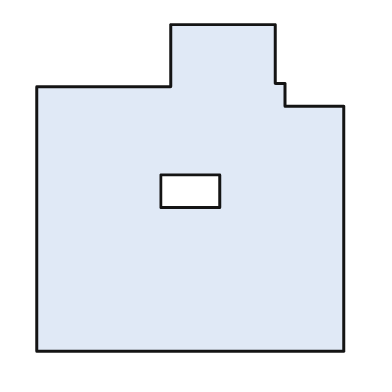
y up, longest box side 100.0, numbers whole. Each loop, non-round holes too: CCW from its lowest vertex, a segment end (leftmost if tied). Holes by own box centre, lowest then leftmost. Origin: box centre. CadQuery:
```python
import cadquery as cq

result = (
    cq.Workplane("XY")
    .moveTo(-47.0, -50.0)
    .lineTo(47.0, -50.0)
    .lineTo(47.0, 25.0)
    .lineTo(29.0, 25.0)
    .lineTo(29.0, 32.0)
    .lineTo(26.0, 32.0)
    .lineTo(26.0, 50.0)
    .lineTo(-6.0, 50.0)
    .lineTo(-6.0, 31.0)
    .lineTo(-47.0, 31.0)
    .close()
    .moveTo(-9.0, -6.0)
    .lineTo(9.0, -6.0)
    .lineTo(9.0, 4.0)
    .lineTo(-9.0, 4.0)
    .close()
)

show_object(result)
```